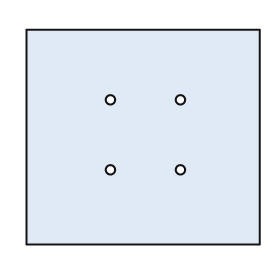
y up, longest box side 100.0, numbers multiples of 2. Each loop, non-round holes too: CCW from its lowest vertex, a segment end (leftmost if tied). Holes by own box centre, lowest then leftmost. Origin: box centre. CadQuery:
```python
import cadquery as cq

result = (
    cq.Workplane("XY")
    .moveTo(-50.0, -46.0)
    .lineTo(50.0, -46.0)
    .lineTo(50.0, 46.0)
    .lineTo(-50.0, 46.0)
    .close()
    .moveTo(-14.0, -14.0)
    .circle(2.0)
    .moveTo(16.0, -14.0)
    .circle(2.0)
    .moveTo(-14.0, 16.0)
    .circle(2.0)
    .moveTo(16.0, 16.0)
    .circle(2.0)
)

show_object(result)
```